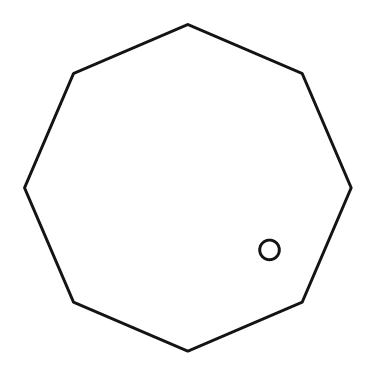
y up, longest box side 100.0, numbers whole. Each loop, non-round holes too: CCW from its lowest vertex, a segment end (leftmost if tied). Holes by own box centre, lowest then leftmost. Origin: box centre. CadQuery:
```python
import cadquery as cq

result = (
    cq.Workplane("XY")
    .moveTo(0.0, -50.0)
    .lineTo(35.0, -35.0)
    .lineTo(50.0, 0.0)
    .lineTo(35.0, 35.0)
    .lineTo(0.0, 50.0)
    .lineTo(-35.0, 35.0)
    .lineTo(-50.0, 0.0)
    .lineTo(-35.0, -35.0)
    .close()
    .moveTo(25.0, -19.0)
    .circle(3.0)
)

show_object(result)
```